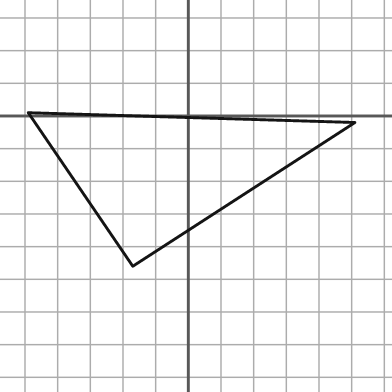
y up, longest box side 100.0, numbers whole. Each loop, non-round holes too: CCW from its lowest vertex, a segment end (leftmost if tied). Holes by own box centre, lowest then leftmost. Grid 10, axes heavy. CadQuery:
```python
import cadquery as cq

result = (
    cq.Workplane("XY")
    .moveTo(-17.0, -46.0)
    .lineTo(51.0, -2.0)
    .lineTo(-49.0, 1.0)
    .close()
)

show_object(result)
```